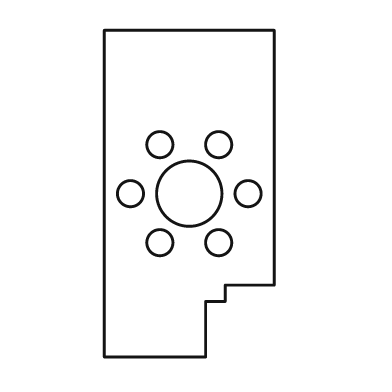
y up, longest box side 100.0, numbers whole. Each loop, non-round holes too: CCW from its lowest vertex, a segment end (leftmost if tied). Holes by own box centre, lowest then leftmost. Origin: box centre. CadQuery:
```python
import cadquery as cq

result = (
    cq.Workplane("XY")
    .moveTo(-26.0, -50.0)
    .lineTo(5.0, -50.0)
    .lineTo(5.0, -33.0)
    .lineTo(11.0, -33.0)
    .lineTo(11.0, -28.0)
    .lineTo(26.0, -28.0)
    .lineTo(26.0, 50.0)
    .lineTo(-26.0, 50.0)
    .close()
    .moveTo(-9.0, -15.0)
    .circle(4.0)
    .moveTo(9.0, -15.0)
    .circle(4.0)
    .moveTo(-18.0, 0.0)
    .circle(4.0)
    .moveTo(0.0, 0.0)
    .circle(10.0)
    .moveTo(18.0, 0.0)
    .circle(4.0)
    .moveTo(-9.0, 15.0)
    .circle(4.0)
    .moveTo(9.0, 15.0)
    .circle(4.0)
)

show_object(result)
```